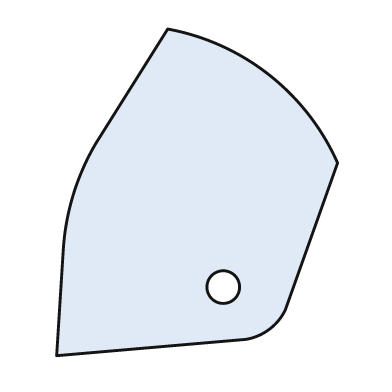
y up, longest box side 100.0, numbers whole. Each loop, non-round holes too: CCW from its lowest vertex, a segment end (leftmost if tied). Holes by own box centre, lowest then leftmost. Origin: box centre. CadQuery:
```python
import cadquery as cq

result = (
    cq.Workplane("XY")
    .moveTo(-43.0, -50.0)
    .lineTo(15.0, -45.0)
    .threePointArc((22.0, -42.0), (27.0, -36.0))
    .lineTo(43.0, 9.0)
    .threePointArc((22.0, 36.0), (-9.0, 50.0))
    .lineTo(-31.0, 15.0)
    .threePointArc((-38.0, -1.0), (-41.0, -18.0))
    .close()
    .moveTo(8.0, -29.0)
    .circle(5.0)
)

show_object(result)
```